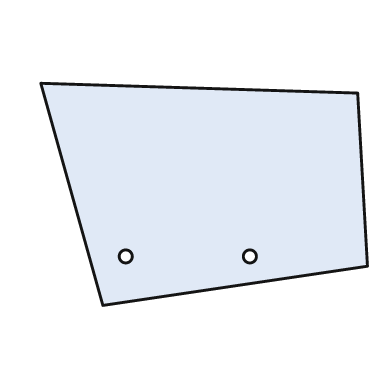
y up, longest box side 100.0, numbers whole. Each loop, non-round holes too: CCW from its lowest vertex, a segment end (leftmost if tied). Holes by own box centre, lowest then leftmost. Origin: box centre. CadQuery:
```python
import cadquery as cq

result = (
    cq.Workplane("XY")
    .moveTo(-31.0, -34.0)
    .lineTo(50.0, -22.0)
    .lineTo(47.0, 31.0)
    .lineTo(-50.0, 34.0)
    .close()
    .moveTo(-24.0, -19.0)
    .circle(2.0)
    .moveTo(14.0, -19.0)
    .circle(2.0)
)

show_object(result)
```